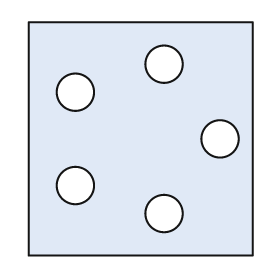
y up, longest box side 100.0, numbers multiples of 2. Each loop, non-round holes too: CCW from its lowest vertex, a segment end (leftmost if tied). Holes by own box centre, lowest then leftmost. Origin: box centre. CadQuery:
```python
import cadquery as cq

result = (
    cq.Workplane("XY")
    .moveTo(-48.0, -50.0)
    .lineTo(48.0, -50.0)
    .lineTo(48.0, 50.0)
    .lineTo(-48.0, 50.0)
    .close()
    .moveTo(10.0, -32.0)
    .circle(8.0)
    .moveTo(-28.0, -20.0)
    .circle(8.0)
    .moveTo(34.0, 0.0)
    .circle(8.0)
    .moveTo(-28.0, 20.0)
    .circle(8.0)
    .moveTo(10.0, 32.0)
    .circle(8.0)
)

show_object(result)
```